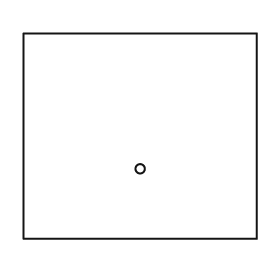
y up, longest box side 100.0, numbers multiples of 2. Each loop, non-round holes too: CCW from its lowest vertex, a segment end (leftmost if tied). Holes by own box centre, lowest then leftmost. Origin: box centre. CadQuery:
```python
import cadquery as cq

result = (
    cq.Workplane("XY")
    .moveTo(-50.0, -44.0)
    .lineTo(50.0, -44.0)
    .lineTo(50.0, 44.0)
    .lineTo(-50.0, 44.0)
    .close()
    .moveTo(0.0, -14.0)
    .circle(2.0)
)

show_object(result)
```